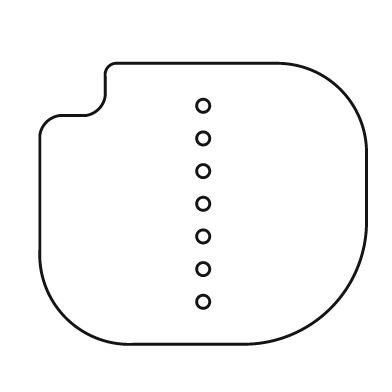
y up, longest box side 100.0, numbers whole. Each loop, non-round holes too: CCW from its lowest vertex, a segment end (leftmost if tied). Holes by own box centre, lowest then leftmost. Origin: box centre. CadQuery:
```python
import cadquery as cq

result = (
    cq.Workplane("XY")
    .moveTo(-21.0, -43.0)
    .lineTo(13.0, -43.0)
    .threePointArc((39.0, -32.0), (50.0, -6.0))
    .lineTo(50.0, 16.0)
    .threePointArc((42.0, 35.0), (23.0, 43.0))
    .lineTo(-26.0, 43.0)
    .threePointArc((-29.0, 42.0), (-30.0, 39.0))
    .lineTo(-30.0, 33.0)
    .threePointArc((-32.0, 29.0), (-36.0, 27.0))
    .lineTo(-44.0, 27.0)
    .threePointArc((-48.0, 25.0), (-50.0, 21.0))
    .lineTo(-50.0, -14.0)
    .threePointArc((-42.0, -35.0), (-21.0, -43.0))
    .close()
    .moveTo(0.0, -30.0)
    .circle(2.0)
    .moveTo(0.0, -20.0)
    .circle(2.0)
    .moveTo(0.0, -10.0)
    .circle(2.0)
    .moveTo(0.0, 0.0)
    .circle(2.0)
    .moveTo(0.0, 10.0)
    .circle(2.0)
    .moveTo(0.0, 20.0)
    .circle(2.0)
    .moveTo(0.0, 30.0)
    .circle(2.0)
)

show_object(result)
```